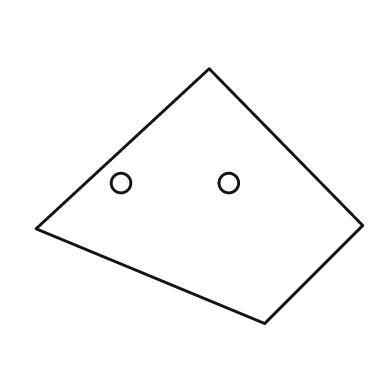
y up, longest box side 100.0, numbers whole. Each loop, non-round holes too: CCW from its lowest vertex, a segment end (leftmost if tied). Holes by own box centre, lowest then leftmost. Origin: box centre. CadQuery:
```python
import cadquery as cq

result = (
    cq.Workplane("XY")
    .moveTo(20.0, -39.0)
    .lineTo(50.0, -9.0)
    .lineTo(3.0, 39.0)
    .lineTo(-50.0, -10.0)
    .close()
    .moveTo(-24.0, 4.0)
    .circle(3.0)
    .moveTo(9.0, 4.0)
    .circle(3.0)
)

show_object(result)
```